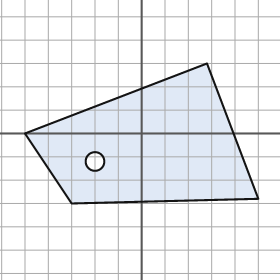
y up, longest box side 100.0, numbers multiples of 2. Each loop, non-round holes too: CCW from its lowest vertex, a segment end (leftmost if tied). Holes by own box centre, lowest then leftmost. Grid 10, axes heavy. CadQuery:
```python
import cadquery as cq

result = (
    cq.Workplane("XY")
    .moveTo(-30.0, -30.0)
    .lineTo(50.0, -28.0)
    .lineTo(28.0, 30.0)
    .lineTo(-50.0, 0.0)
    .close()
    .moveTo(-20.0, -12.0)
    .circle(4.0)
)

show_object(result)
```